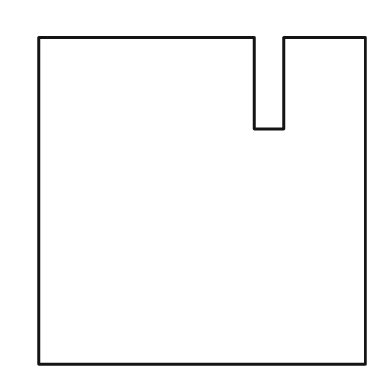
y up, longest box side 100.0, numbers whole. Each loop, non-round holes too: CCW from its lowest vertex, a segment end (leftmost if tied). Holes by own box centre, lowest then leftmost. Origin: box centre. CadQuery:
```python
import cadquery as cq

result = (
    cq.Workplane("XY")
    .moveTo(-50.0, -50.0)
    .lineTo(50.0, -50.0)
    .lineTo(50.0, 50.0)
    .lineTo(25.0, 50.0)
    .lineTo(25.0, 22.0)
    .lineTo(16.0, 22.0)
    .lineTo(16.0, 50.0)
    .lineTo(-50.0, 50.0)
    .close()
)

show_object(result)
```